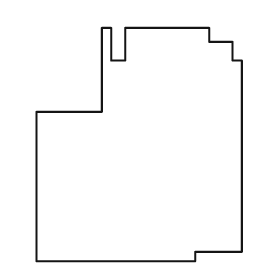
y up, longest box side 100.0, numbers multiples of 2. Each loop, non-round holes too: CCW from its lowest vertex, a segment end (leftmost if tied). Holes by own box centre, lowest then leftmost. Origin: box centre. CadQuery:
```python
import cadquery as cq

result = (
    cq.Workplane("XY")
    .moveTo(-44.0, -50.0)
    .lineTo(24.0, -50.0)
    .lineTo(24.0, -46.0)
    .lineTo(44.0, -46.0)
    .lineTo(44.0, 36.0)
    .lineTo(40.0, 36.0)
    .lineTo(40.0, 44.0)
    .lineTo(30.0, 44.0)
    .lineTo(30.0, 50.0)
    .lineTo(-6.0, 50.0)
    .lineTo(-6.0, 36.0)
    .lineTo(-12.0, 36.0)
    .lineTo(-12.0, 50.0)
    .lineTo(-16.0, 50.0)
    .lineTo(-16.0, 14.0)
    .lineTo(-44.0, 14.0)
    .close()
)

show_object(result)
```